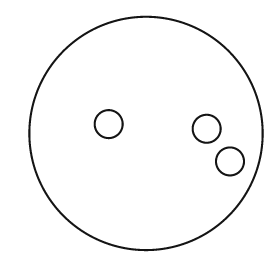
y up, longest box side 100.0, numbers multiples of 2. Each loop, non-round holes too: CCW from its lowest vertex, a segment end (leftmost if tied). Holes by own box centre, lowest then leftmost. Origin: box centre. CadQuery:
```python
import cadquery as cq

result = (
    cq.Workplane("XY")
    .moveTo(0.0, 0.0)
    .circle(50.0)
    .moveTo(36.0, -12.0)
    .circle(6.0)
    .moveTo(26.0, 2.0)
    .circle(6.0)
    .moveTo(-16.0, 4.0)
    .circle(6.0)
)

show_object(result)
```